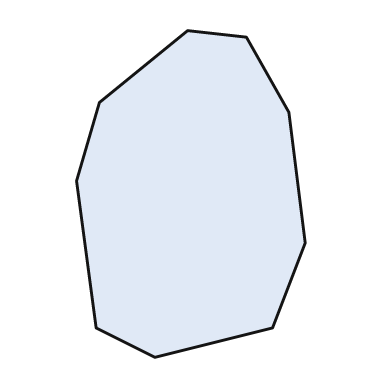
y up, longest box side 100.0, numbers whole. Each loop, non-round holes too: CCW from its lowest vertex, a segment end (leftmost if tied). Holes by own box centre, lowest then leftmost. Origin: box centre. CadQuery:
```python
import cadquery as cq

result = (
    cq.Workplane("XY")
    .moveTo(-11.0, -50.0)
    .lineTo(25.0, -41.0)
    .lineTo(35.0, -15.0)
    .lineTo(30.0, 25.0)
    .lineTo(17.0, 48.0)
    .lineTo(-1.0, 50.0)
    .lineTo(-28.0, 28.0)
    .lineTo(-35.0, 4.0)
    .lineTo(-29.0, -41.0)
    .close()
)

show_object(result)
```